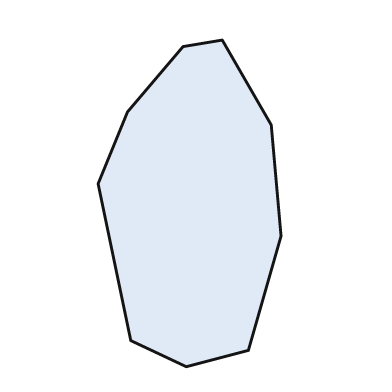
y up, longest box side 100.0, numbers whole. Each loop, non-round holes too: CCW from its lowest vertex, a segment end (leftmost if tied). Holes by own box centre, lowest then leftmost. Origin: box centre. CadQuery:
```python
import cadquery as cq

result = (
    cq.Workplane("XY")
    .moveTo(-1.0, -50.0)
    .lineTo(18.0, -45.0)
    .lineTo(28.0, -10.0)
    .lineTo(25.0, 24.0)
    .lineTo(10.0, 50.0)
    .lineTo(-2.0, 48.0)
    .lineTo(-19.0, 28.0)
    .lineTo(-28.0, 6.0)
    .lineTo(-18.0, -42.0)
    .close()
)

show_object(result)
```